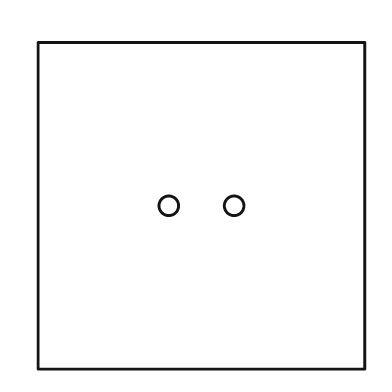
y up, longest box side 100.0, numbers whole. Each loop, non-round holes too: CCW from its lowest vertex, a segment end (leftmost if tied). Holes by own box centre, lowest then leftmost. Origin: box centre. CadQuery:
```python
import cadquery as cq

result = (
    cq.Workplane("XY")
    .moveTo(-50.0, -50.0)
    .lineTo(50.0, -50.0)
    .lineTo(50.0, 50.0)
    .lineTo(-50.0, 50.0)
    .close()
    .moveTo(-10.0, 0.0)
    .circle(3.0)
    .moveTo(10.0, 0.0)
    .circle(3.0)
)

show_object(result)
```